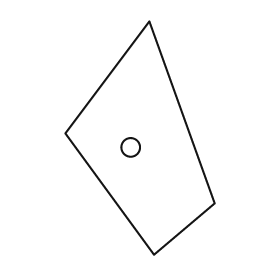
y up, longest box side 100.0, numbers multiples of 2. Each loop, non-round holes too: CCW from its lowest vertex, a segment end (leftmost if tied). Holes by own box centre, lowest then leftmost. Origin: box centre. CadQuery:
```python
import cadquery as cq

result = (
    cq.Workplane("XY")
    .moveTo(6.0, -50.0)
    .lineTo(32.0, -28.0)
    .lineTo(4.0, 50.0)
    .lineTo(-32.0, 2.0)
    .close()
    .moveTo(-4.0, -4.0)
    .circle(4.0)
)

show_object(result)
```